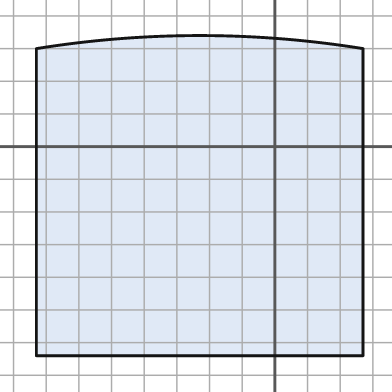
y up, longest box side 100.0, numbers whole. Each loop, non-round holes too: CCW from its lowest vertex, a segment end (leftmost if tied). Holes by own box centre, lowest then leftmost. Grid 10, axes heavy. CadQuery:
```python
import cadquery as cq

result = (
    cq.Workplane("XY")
    .moveTo(-73.0, -64.0)
    .lineTo(27.0, -64.0)
    .lineTo(27.0, 30.0)
    .threePointArc((-23.0, 34.0), (-73.0, 30.0))
    .close()
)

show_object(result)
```